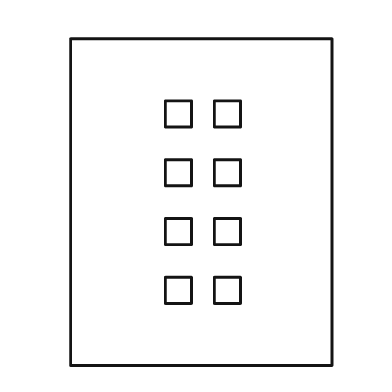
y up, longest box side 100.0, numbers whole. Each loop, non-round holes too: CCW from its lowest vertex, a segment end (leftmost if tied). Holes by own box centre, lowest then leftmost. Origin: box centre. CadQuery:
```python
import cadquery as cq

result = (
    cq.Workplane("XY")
    .moveTo(-40.0, -50.0)
    .lineTo(40.0, -50.0)
    .lineTo(40.0, 50.0)
    .lineTo(-40.0, 50.0)
    .close()
    .moveTo(-11.0, -31.0)
    .lineTo(-3.0, -31.0)
    .lineTo(-3.0, -23.0)
    .lineTo(-11.0, -23.0)
    .close()
    .moveTo(4.0, -31.0)
    .lineTo(12.0, -31.0)
    .lineTo(12.0, -23.0)
    .lineTo(4.0, -23.0)
    .close()
    .moveTo(-11.0, -13.0)
    .lineTo(-3.0, -13.0)
    .lineTo(-3.0, -5.0)
    .lineTo(-11.0, -5.0)
    .close()
    .moveTo(4.0, -13.0)
    .lineTo(12.0, -13.0)
    .lineTo(12.0, -5.0)
    .lineTo(4.0, -5.0)
    .close()
    .moveTo(-11.0, 5.0)
    .lineTo(-3.0, 5.0)
    .lineTo(-3.0, 13.0)
    .lineTo(-11.0, 13.0)
    .close()
    .moveTo(4.0, 5.0)
    .lineTo(12.0, 5.0)
    .lineTo(12.0, 13.0)
    .lineTo(4.0, 13.0)
    .close()
    .moveTo(-11.0, 23.0)
    .lineTo(-3.0, 23.0)
    .lineTo(-3.0, 31.0)
    .lineTo(-11.0, 31.0)
    .close()
    .moveTo(4.0, 23.0)
    .lineTo(12.0, 23.0)
    .lineTo(12.0, 31.0)
    .lineTo(4.0, 31.0)
    .close()
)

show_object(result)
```